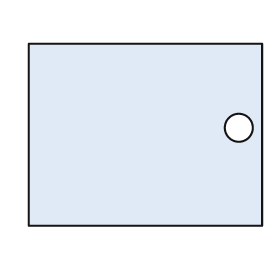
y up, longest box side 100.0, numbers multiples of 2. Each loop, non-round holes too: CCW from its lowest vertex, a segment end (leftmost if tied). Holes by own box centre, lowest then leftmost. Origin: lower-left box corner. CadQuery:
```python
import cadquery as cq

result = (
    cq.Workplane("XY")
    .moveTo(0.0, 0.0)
    .lineTo(100.0, 0.0)
    .lineTo(100.0, 78.0)
    .lineTo(0.0, 78.0)
    .close()
    .moveTo(90.0, 42.0)
    .circle(6.0)
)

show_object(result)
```